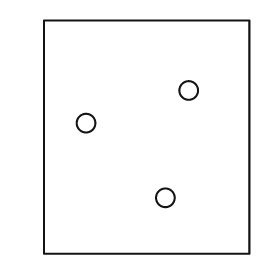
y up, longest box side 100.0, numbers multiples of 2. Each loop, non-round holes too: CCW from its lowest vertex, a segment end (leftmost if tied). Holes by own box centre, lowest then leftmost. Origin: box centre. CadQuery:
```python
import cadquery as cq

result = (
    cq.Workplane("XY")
    .moveTo(-44.0, -50.0)
    .lineTo(44.0, -50.0)
    .lineTo(44.0, 50.0)
    .lineTo(-44.0, 50.0)
    .close()
    .moveTo(8.0, -26.0)
    .circle(4.0)
    .moveTo(-26.0, 6.0)
    .circle(4.0)
    .moveTo(18.0, 20.0)
    .circle(4.0)
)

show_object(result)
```